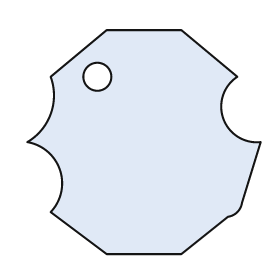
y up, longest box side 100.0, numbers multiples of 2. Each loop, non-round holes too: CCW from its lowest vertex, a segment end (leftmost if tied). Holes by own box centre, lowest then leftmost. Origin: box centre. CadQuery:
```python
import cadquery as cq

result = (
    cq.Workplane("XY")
    .moveTo(-16.0, -48.0)
    .lineTo(16.0, -48.0)
    .lineTo(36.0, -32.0)
    .threePointArc((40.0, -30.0), (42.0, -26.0))
    .lineTo(50.0, 0.0)
    .threePointArc((34.0, 10.0), (40.0, 28.0))
    .lineTo(16.0, 48.0)
    .lineTo(-16.0, 48.0)
    .lineTo(-40.0, 28.0)
    .threePointArc((-40.0, 12.0), (-50.0, 0.0))
    .threePointArc((-36.0, -12.0), (-40.0, -30.0))
    .close()
    .moveTo(-20.0, 28.0)
    .circle(6.0)
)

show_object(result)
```